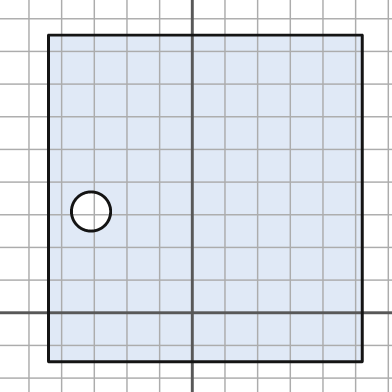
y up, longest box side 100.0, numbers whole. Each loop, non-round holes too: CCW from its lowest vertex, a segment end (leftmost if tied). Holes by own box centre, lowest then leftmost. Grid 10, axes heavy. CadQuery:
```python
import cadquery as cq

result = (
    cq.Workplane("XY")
    .moveTo(-44.0, -15.0)
    .lineTo(52.0, -15.0)
    .lineTo(52.0, 85.0)
    .lineTo(-44.0, 85.0)
    .close()
    .moveTo(-31.0, 31.0)
    .circle(6.0)
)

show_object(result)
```